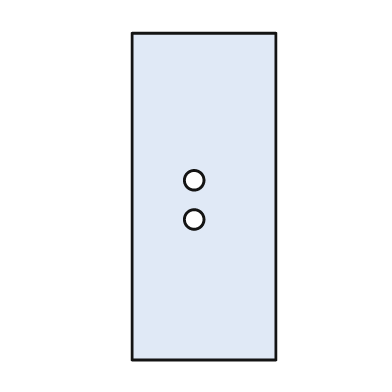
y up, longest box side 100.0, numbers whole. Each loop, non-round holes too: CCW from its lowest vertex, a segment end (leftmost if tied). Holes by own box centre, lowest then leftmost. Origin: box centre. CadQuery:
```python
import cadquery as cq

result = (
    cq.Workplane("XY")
    .moveTo(-22.0, -50.0)
    .lineTo(22.0, -50.0)
    .lineTo(22.0, 50.0)
    .lineTo(-22.0, 50.0)
    .close()
    .moveTo(-3.0, -7.0)
    .circle(3.0)
    .moveTo(-3.0, 5.0)
    .circle(3.0)
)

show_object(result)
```